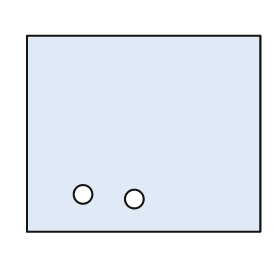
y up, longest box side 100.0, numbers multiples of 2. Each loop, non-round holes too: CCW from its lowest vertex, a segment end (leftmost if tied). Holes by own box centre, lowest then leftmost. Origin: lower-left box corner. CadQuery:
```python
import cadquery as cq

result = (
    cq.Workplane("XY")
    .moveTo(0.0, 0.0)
    .lineTo(100.0, 0.0)
    .lineTo(100.0, 84.0)
    .lineTo(0.0, 84.0)
    .close()
    .moveTo(46.0, 14.0)
    .circle(4.0)
    .moveTo(24.0, 16.0)
    .circle(4.0)
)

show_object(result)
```